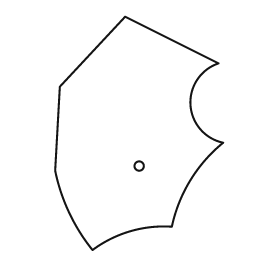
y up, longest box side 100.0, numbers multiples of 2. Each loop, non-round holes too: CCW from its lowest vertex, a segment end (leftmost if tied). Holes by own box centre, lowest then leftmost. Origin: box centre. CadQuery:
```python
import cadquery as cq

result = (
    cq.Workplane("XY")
    .moveTo(-20.0, -50.0)
    .threePointArc((-4.0, -42.0), (14.0, -40.0))
    .threePointArc((22.0, -20.0), (36.0, -4.0))
    .threePointArc((22.0, 12.0), (34.0, 30.0))
    .lineTo(-6.0, 50.0)
    .lineTo(-34.0, 20.0)
    .lineTo(-36.0, -16.0)
    .threePointArc((-30.0, -34.0), (-20.0, -50.0))
    .close()
    .moveTo(0.0, -14.0)
    .circle(2.0)
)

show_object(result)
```